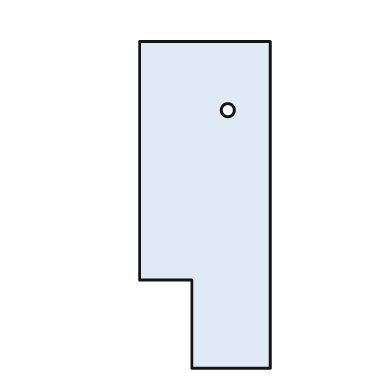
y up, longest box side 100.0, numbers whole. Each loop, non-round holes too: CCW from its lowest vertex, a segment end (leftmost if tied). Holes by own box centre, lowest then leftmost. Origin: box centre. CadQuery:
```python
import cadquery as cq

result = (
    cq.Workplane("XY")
    .moveTo(-4.0, -50.0)
    .lineTo(20.0, -50.0)
    .lineTo(20.0, 50.0)
    .lineTo(-20.0, 50.0)
    .lineTo(-20.0, -23.0)
    .lineTo(-4.0, -23.0)
    .close()
    .moveTo(7.0, 29.0)
    .circle(2.0)
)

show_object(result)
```